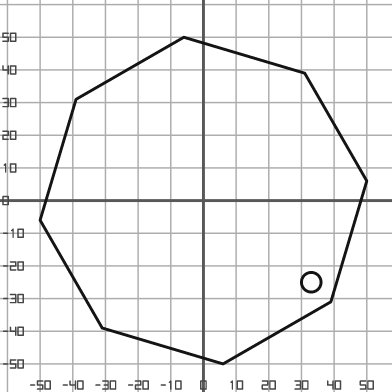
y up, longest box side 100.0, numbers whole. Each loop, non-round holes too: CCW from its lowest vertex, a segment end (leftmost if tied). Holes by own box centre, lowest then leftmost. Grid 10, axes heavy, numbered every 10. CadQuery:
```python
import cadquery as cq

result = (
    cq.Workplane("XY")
    .moveTo(6.0, -50.0)
    .lineTo(39.0, -31.0)
    .lineTo(50.0, 6.0)
    .lineTo(31.0, 39.0)
    .lineTo(-6.0, 50.0)
    .lineTo(-39.0, 31.0)
    .lineTo(-50.0, -6.0)
    .lineTo(-31.0, -39.0)
    .close()
    .moveTo(33.0, -25.0)
    .circle(3.0)
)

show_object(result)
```